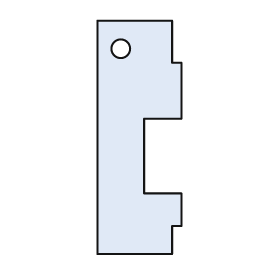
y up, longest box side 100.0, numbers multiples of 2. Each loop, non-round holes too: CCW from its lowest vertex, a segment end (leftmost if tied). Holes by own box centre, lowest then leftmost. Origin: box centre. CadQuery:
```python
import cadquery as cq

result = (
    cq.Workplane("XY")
    .moveTo(-18.0, -50.0)
    .lineTo(14.0, -50.0)
    .lineTo(14.0, -38.0)
    .lineTo(18.0, -38.0)
    .lineTo(18.0, -24.0)
    .lineTo(2.0, -24.0)
    .lineTo(2.0, 8.0)
    .lineTo(18.0, 8.0)
    .lineTo(18.0, 32.0)
    .lineTo(14.0, 32.0)
    .lineTo(14.0, 50.0)
    .lineTo(-18.0, 50.0)
    .close()
    .moveTo(-8.0, 38.0)
    .circle(4.0)
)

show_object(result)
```